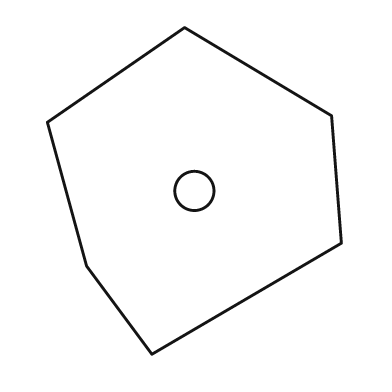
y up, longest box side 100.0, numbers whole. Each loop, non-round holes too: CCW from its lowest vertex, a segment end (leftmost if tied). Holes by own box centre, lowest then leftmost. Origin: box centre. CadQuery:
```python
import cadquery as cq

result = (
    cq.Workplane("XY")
    .moveTo(-13.0, -50.0)
    .lineTo(45.0, -16.0)
    .lineTo(42.0, 23.0)
    .lineTo(-3.0, 50.0)
    .lineTo(-45.0, 21.0)
    .lineTo(-33.0, -23.0)
    .close()
    .moveTo(0.0, 0.0)
    .circle(6.0)
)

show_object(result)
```